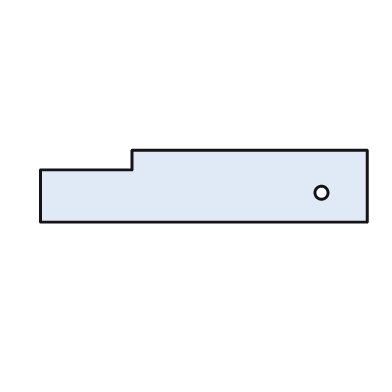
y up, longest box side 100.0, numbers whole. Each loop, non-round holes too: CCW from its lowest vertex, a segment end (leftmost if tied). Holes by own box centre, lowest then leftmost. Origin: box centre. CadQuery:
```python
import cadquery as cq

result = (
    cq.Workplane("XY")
    .moveTo(-50.0, -11.0)
    .lineTo(50.0, -11.0)
    .lineTo(50.0, 11.0)
    .lineTo(-22.0, 11.0)
    .lineTo(-22.0, 5.0)
    .lineTo(-50.0, 5.0)
    .close()
    .moveTo(36.0, -2.0)
    .circle(2.0)
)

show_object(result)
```